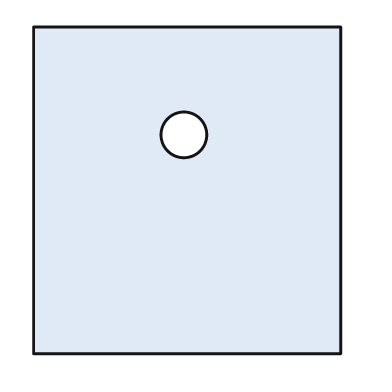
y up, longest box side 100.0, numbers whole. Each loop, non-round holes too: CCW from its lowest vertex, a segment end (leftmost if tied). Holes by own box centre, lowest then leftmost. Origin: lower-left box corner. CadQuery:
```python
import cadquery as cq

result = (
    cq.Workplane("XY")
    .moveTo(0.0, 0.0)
    .lineTo(94.0, 0.0)
    .lineTo(94.0, 100.0)
    .lineTo(0.0, 100.0)
    .close()
    .moveTo(46.0, 67.0)
    .circle(7.0)
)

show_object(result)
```